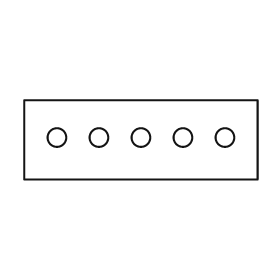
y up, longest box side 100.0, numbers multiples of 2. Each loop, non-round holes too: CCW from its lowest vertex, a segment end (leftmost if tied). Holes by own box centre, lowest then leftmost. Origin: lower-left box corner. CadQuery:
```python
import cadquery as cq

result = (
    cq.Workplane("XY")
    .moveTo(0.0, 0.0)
    .lineTo(100.0, 0.0)
    .lineTo(100.0, 34.0)
    .lineTo(0.0, 34.0)
    .close()
    .moveTo(14.0, 18.0)
    .circle(4.0)
    .moveTo(32.0, 18.0)
    .circle(4.0)
    .moveTo(50.0, 18.0)
    .circle(4.0)
    .moveTo(68.0, 18.0)
    .circle(4.0)
    .moveTo(86.0, 18.0)
    .circle(4.0)
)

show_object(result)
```